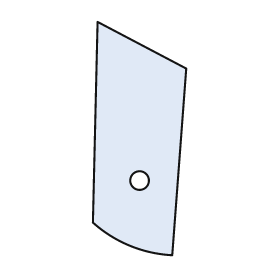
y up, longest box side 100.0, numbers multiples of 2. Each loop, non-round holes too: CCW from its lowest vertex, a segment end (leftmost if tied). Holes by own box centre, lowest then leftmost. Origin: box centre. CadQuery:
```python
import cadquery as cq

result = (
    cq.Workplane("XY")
    .moveTo(14.0, -50.0)
    .lineTo(20.0, 30.0)
    .lineTo(-18.0, 50.0)
    .lineTo(-20.0, -36.0)
    .threePointArc((-4.0, -46.0), (14.0, -50.0))
    .close()
    .moveTo(0.0, -18.0)
    .circle(4.0)
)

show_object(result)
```